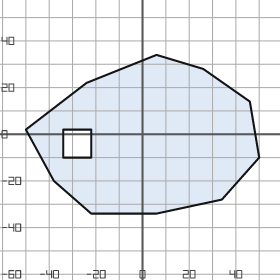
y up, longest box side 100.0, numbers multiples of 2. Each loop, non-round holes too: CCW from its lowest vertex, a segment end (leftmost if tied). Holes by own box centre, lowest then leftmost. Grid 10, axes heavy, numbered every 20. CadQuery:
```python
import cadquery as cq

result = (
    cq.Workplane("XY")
    .moveTo(-22.0, -34.0)
    .lineTo(6.0, -34.0)
    .lineTo(34.0, -28.0)
    .lineTo(50.0, -10.0)
    .lineTo(46.0, 14.0)
    .lineTo(26.0, 28.0)
    .lineTo(6.0, 34.0)
    .lineTo(-24.0, 22.0)
    .lineTo(-50.0, 2.0)
    .lineTo(-38.0, -20.0)
    .close()
    .moveTo(-34.0, -10.0)
    .lineTo(-22.0, -10.0)
    .lineTo(-22.0, 2.0)
    .lineTo(-34.0, 2.0)
    .close()
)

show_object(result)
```